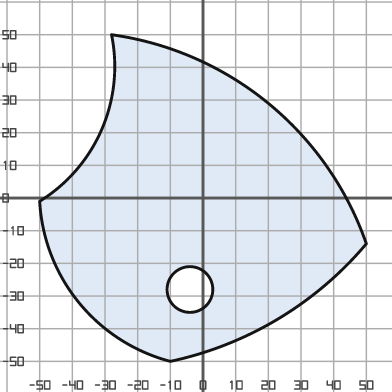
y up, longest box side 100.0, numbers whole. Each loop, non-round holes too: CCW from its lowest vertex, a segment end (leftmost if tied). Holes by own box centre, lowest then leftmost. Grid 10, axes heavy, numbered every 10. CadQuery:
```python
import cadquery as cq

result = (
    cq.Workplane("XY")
    .moveTo(-10.0, -50.0)
    .threePointArc((23.0, -37.0), (50.0, -14.0))
    .threePointArc((20.0, 29.0), (-28.0, 50.0))
    .threePointArc((-31.0, 21.0), (-50.0, -1.0))
    .threePointArc((-38.0, -32.0), (-10.0, -50.0))
    .close()
    .moveTo(-4.0, -28.0)
    .circle(7.0)
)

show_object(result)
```